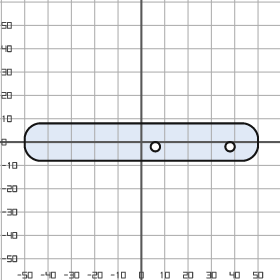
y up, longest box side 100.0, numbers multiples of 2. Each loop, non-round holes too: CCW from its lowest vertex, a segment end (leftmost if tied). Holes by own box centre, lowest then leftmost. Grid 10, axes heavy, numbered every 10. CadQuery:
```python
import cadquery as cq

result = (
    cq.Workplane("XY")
    .moveTo(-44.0, -8.0)
    .lineTo(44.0, -8.0)
    .threePointArc((48.0, -6.0), (50.0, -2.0))
    .lineTo(50.0, 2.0)
    .threePointArc((48.0, 6.0), (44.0, 8.0))
    .lineTo(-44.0, 8.0)
    .threePointArc((-48.0, 6.0), (-50.0, 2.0))
    .lineTo(-50.0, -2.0)
    .threePointArc((-48.0, -6.0), (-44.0, -8.0))
    .close()
    .moveTo(6.0, -2.0)
    .circle(2.0)
    .moveTo(38.0, -2.0)
    .circle(2.0)
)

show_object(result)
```